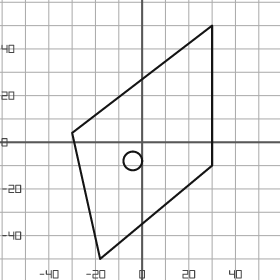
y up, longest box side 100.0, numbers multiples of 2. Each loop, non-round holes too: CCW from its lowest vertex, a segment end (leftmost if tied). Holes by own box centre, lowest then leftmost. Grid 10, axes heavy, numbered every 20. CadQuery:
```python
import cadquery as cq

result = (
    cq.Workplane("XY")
    .moveTo(-18.0, -50.0)
    .lineTo(30.0, -10.0)
    .lineTo(30.0, 50.0)
    .lineTo(-30.0, 4.0)
    .close()
    .moveTo(-4.0, -8.0)
    .circle(4.0)
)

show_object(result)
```